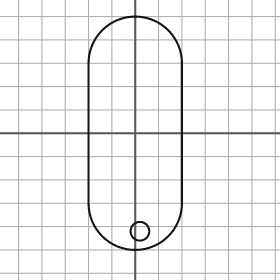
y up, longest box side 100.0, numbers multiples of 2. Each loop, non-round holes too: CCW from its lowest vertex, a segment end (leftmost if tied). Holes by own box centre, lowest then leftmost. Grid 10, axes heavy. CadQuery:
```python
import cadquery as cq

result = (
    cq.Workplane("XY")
    .moveTo(-20.0, -30.0)
    .threePointArc((0.0, -50.0), (20.0, -30.0))
    .lineTo(20.0, 30.0)
    .threePointArc((0.0, 50.0), (-20.0, 30.0))
    .close()
    .moveTo(2.0, -42.0)
    .circle(4.0)
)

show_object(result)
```